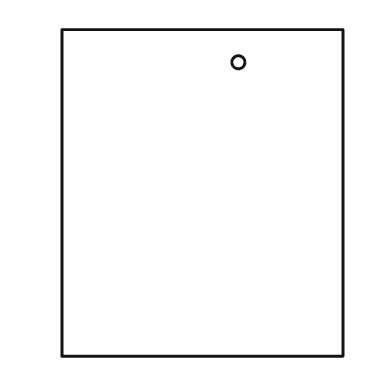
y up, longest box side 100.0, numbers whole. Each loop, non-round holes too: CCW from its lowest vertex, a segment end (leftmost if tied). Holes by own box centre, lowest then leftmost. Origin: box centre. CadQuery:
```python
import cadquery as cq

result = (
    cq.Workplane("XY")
    .moveTo(-43.0, -50.0)
    .lineTo(43.0, -50.0)
    .lineTo(43.0, 50.0)
    .lineTo(-43.0, 50.0)
    .close()
    .moveTo(11.0, 40.0)
    .circle(2.0)
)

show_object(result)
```